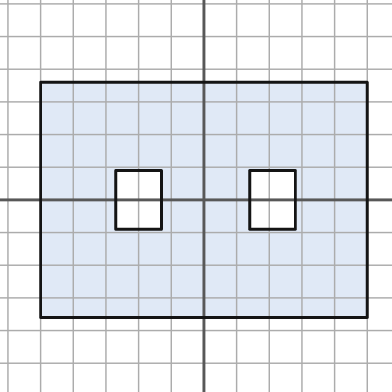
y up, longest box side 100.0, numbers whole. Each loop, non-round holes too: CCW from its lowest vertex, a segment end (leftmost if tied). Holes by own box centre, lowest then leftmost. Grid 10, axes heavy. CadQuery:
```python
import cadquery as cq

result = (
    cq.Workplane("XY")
    .moveTo(-50.0, -36.0)
    .lineTo(50.0, -36.0)
    .lineTo(50.0, 36.0)
    .lineTo(-50.0, 36.0)
    .close()
    .moveTo(-27.0, -9.0)
    .lineTo(-13.0, -9.0)
    .lineTo(-13.0, 9.0)
    .lineTo(-27.0, 9.0)
    .close()
    .moveTo(14.0, -9.0)
    .lineTo(28.0, -9.0)
    .lineTo(28.0, 9.0)
    .lineTo(14.0, 9.0)
    .close()
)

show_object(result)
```